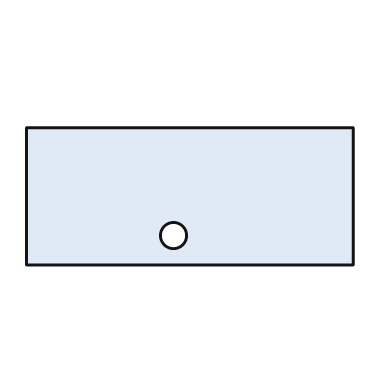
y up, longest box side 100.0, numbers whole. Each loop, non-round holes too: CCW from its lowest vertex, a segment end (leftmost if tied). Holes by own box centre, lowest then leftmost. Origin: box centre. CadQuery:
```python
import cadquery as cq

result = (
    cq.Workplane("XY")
    .moveTo(-50.0, -21.0)
    .lineTo(50.0, -21.0)
    .lineTo(50.0, 21.0)
    .lineTo(-50.0, 21.0)
    .close()
    .moveTo(-5.0, -12.0)
    .circle(4.0)
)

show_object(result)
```